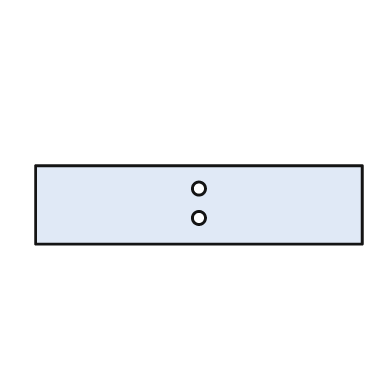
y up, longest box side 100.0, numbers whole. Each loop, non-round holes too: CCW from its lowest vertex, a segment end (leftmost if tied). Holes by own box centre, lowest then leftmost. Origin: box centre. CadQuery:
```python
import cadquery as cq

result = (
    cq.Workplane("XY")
    .moveTo(-50.0, -12.0)
    .lineTo(50.0, -12.0)
    .lineTo(50.0, 12.0)
    .lineTo(-50.0, 12.0)
    .close()
    .moveTo(0.0, -4.0)
    .circle(2.0)
    .moveTo(0.0, 5.0)
    .circle(2.0)
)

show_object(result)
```